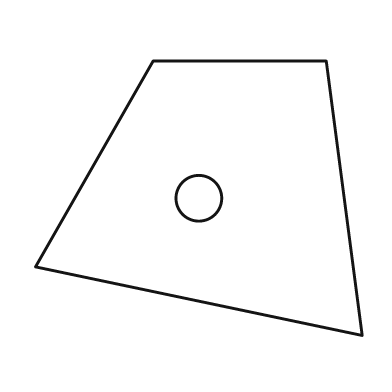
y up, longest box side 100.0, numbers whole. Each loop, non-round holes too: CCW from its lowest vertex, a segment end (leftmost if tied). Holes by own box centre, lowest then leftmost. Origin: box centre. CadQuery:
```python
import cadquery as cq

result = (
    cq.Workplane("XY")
    .moveTo(50.0, -42.0)
    .lineTo(39.0, 42.0)
    .lineTo(-14.0, 42.0)
    .lineTo(-50.0, -21.0)
    .close()
    .moveTo(0.0, 0.0)
    .circle(7.0)
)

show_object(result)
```